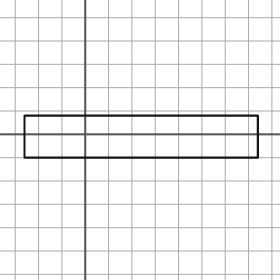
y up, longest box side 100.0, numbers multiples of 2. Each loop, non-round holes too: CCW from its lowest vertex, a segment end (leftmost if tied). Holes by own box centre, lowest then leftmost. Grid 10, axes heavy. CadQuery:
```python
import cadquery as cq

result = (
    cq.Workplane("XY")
    .moveTo(-26.0, -10.0)
    .lineTo(74.0, -10.0)
    .lineTo(74.0, 8.0)
    .lineTo(-26.0, 8.0)
    .close()
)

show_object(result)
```